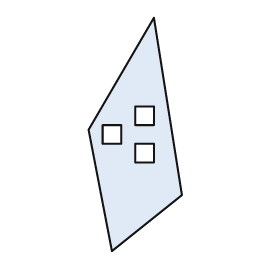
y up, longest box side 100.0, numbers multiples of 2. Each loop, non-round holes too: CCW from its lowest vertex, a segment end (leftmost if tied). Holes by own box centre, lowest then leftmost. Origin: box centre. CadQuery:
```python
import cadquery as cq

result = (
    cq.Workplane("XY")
    .moveTo(-10.0, -50.0)
    .lineTo(20.0, -26.0)
    .lineTo(8.0, 50.0)
    .lineTo(-20.0, 2.0)
    .close()
    .moveTo(0.0, -12.0)
    .lineTo(8.0, -12.0)
    .lineTo(8.0, -4.0)
    .lineTo(0.0, -4.0)
    .close()
    .moveTo(-14.0, -4.0)
    .lineTo(-6.0, -4.0)
    .lineTo(-6.0, 4.0)
    .lineTo(-14.0, 4.0)
    .close()
    .moveTo(0.0, 4.0)
    .lineTo(8.0, 4.0)
    .lineTo(8.0, 12.0)
    .lineTo(0.0, 12.0)
    .close()
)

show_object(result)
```